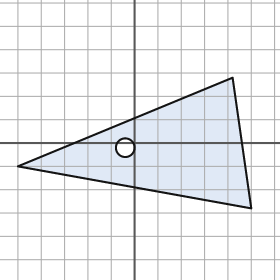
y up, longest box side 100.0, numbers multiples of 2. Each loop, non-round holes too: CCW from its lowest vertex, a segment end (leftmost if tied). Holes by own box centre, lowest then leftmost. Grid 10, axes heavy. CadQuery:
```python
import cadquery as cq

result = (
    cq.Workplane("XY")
    .moveTo(50.0, -28.0)
    .lineTo(42.0, 28.0)
    .lineTo(-50.0, -10.0)
    .close()
    .moveTo(-4.0, -2.0)
    .circle(4.0)
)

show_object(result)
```